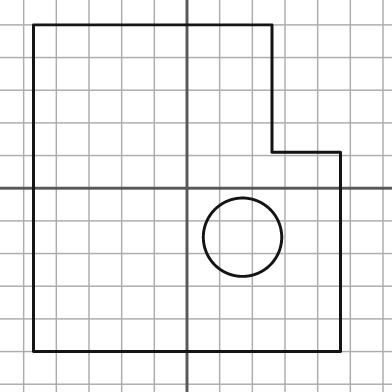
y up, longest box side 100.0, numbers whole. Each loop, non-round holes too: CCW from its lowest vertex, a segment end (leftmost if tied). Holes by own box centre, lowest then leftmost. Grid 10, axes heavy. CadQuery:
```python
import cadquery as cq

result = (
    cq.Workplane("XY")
    .moveTo(-47.0, -50.0)
    .lineTo(47.0, -50.0)
    .lineTo(47.0, 11.0)
    .lineTo(26.0, 11.0)
    .lineTo(26.0, 50.0)
    .lineTo(-47.0, 50.0)
    .close()
    .moveTo(17.0, -15.0)
    .circle(12.0)
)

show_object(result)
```